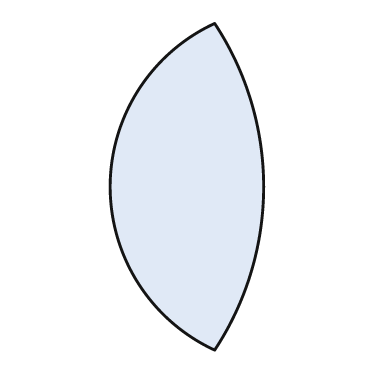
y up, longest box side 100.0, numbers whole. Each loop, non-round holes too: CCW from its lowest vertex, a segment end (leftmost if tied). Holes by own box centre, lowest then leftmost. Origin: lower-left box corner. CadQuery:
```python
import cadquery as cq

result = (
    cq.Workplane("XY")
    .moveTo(32.0, 0.0)
    .threePointArc((47.0, 50.0), (32.0, 100.0))
    .threePointArc((0.0, 50.0), (32.0, 0.0))
    .close()
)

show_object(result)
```